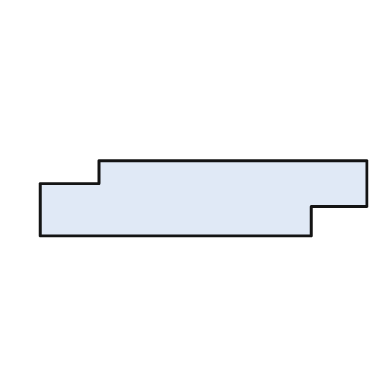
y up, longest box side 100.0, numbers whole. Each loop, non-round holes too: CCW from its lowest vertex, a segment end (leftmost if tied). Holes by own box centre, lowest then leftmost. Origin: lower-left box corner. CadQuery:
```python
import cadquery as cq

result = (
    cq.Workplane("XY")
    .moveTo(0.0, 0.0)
    .lineTo(83.0, 0.0)
    .lineTo(83.0, 9.0)
    .lineTo(100.0, 9.0)
    .lineTo(100.0, 23.0)
    .lineTo(18.0, 23.0)
    .lineTo(18.0, 16.0)
    .lineTo(0.0, 16.0)
    .close()
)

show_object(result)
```